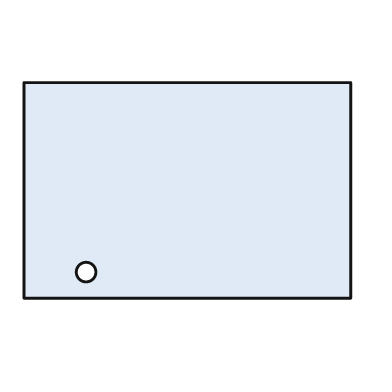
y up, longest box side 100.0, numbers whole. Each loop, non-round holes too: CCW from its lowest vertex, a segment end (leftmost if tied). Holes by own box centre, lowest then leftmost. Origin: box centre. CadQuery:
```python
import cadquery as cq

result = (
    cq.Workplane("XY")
    .moveTo(-50.0, -33.0)
    .lineTo(50.0, -33.0)
    .lineTo(50.0, 33.0)
    .lineTo(-50.0, 33.0)
    .close()
    .moveTo(-31.0, -25.0)
    .circle(3.0)
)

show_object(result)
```